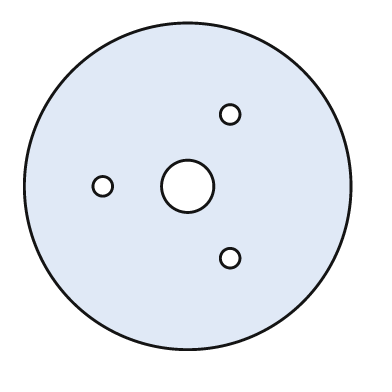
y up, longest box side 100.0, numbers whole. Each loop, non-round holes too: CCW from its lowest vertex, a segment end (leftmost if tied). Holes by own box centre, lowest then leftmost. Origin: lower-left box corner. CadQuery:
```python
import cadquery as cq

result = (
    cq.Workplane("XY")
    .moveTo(50.0, 50.0)
    .circle(50.0)
    .moveTo(63.0, 28.0)
    .circle(3.0)
    .moveTo(24.0, 50.0)
    .circle(3.0)
    .moveTo(50.0, 50.0)
    .circle(8.0)
    .moveTo(63.0, 72.0)
    .circle(3.0)
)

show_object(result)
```